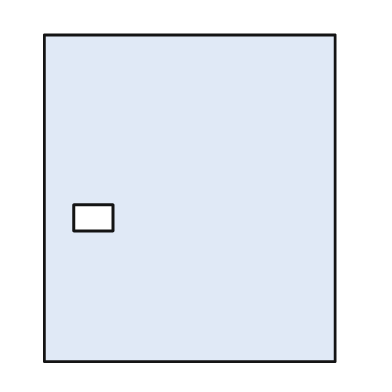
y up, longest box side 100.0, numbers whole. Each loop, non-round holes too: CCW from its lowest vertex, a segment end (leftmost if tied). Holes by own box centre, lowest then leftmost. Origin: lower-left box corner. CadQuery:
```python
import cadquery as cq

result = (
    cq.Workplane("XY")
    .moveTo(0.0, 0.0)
    .lineTo(89.0, 0.0)
    .lineTo(89.0, 100.0)
    .lineTo(0.0, 100.0)
    .close()
    .moveTo(9.0, 40.0)
    .lineTo(21.0, 40.0)
    .lineTo(21.0, 48.0)
    .lineTo(9.0, 48.0)
    .close()
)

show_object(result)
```